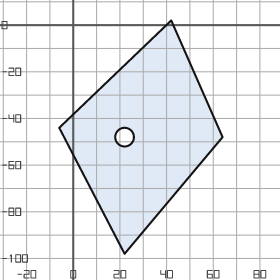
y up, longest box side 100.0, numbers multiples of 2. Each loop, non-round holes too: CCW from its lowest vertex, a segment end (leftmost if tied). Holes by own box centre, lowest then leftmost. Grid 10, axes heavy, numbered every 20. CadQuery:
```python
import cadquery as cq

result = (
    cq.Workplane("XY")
    .moveTo(22.0, -98.0)
    .lineTo(64.0, -48.0)
    .lineTo(42.0, 2.0)
    .lineTo(-6.0, -44.0)
    .close()
    .moveTo(22.0, -48.0)
    .circle(4.0)
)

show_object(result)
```